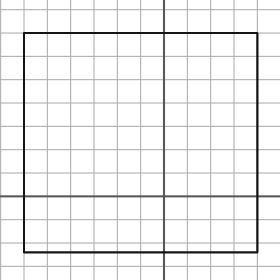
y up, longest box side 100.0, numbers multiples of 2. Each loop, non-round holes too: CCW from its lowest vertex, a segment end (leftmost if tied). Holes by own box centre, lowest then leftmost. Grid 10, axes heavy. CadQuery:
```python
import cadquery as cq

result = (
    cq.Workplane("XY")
    .moveTo(-60.0, -24.0)
    .lineTo(40.0, -24.0)
    .lineTo(40.0, 70.0)
    .lineTo(-60.0, 70.0)
    .close()
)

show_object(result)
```